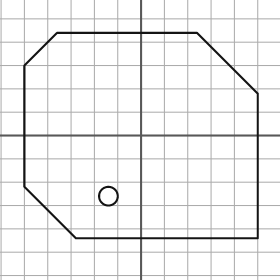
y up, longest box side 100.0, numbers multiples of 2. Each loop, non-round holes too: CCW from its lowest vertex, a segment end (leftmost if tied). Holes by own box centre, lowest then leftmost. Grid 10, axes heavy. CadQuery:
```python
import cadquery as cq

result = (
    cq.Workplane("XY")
    .moveTo(-28.0, -44.0)
    .lineTo(50.0, -44.0)
    .lineTo(50.0, 18.0)
    .lineTo(24.0, 44.0)
    .lineTo(-36.0, 44.0)
    .lineTo(-50.0, 30.0)
    .lineTo(-50.0, -22.0)
    .close()
    .moveTo(-14.0, -26.0)
    .circle(4.0)
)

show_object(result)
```